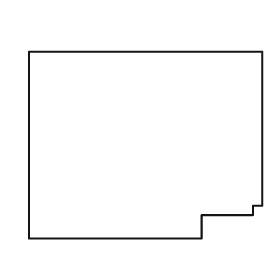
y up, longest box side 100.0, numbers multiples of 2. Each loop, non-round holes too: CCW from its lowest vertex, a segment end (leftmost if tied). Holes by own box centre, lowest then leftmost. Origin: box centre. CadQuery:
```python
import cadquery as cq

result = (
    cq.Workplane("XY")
    .moveTo(-50.0, -40.0)
    .lineTo(24.0, -40.0)
    .lineTo(24.0, -30.0)
    .lineTo(46.0, -30.0)
    .lineTo(46.0, -26.0)
    .lineTo(50.0, -26.0)
    .lineTo(50.0, 40.0)
    .lineTo(-50.0, 40.0)
    .close()
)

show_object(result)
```